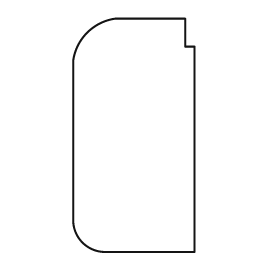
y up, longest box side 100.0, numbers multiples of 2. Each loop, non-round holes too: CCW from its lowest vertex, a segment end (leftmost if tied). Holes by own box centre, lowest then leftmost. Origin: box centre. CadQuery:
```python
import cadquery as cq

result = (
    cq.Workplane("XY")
    .moveTo(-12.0, -50.0)
    .lineTo(26.0, -50.0)
    .lineTo(26.0, 38.0)
    .lineTo(22.0, 38.0)
    .lineTo(22.0, 50.0)
    .lineTo(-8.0, 50.0)
    .threePointArc((-20.0, 44.0), (-26.0, 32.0))
    .lineTo(-26.0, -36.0)
    .threePointArc((-22.0, -46.0), (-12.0, -50.0))
    .close()
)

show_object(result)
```